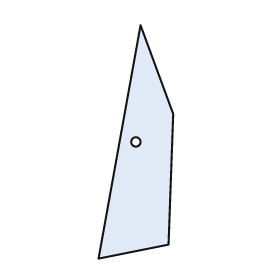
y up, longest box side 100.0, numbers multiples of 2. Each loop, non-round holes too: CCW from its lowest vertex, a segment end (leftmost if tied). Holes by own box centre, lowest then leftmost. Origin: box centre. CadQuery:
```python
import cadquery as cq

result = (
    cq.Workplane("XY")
    .moveTo(-16.0, -50.0)
    .lineTo(14.0, -44.0)
    .lineTo(16.0, 12.0)
    .lineTo(2.0, 50.0)
    .close()
    .moveTo(0.0, 0.0)
    .circle(2.0)
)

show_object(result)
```